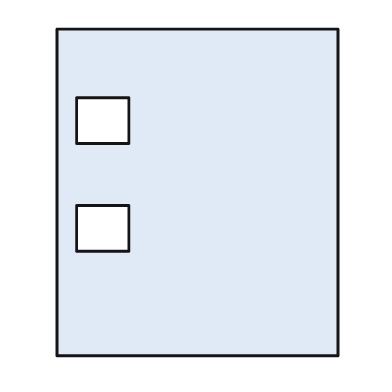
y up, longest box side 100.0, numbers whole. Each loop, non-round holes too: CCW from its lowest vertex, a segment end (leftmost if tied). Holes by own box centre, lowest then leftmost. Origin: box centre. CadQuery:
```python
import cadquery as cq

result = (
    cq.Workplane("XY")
    .moveTo(-43.0, -50.0)
    .lineTo(43.0, -50.0)
    .lineTo(43.0, 50.0)
    .lineTo(-43.0, 50.0)
    .close()
    .moveTo(-37.0, -18.0)
    .lineTo(-21.0, -18.0)
    .lineTo(-21.0, -4.0)
    .lineTo(-37.0, -4.0)
    .close()
    .moveTo(-37.0, 15.0)
    .lineTo(-21.0, 15.0)
    .lineTo(-21.0, 29.0)
    .lineTo(-37.0, 29.0)
    .close()
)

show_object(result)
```